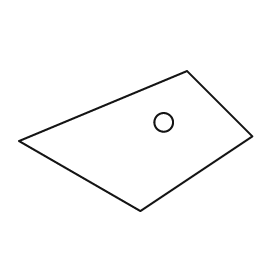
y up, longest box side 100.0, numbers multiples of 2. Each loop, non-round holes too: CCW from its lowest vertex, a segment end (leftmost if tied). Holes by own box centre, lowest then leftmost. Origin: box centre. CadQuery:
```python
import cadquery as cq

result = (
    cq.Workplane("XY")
    .moveTo(2.0, -30.0)
    .lineTo(50.0, 2.0)
    .lineTo(22.0, 30.0)
    .lineTo(-50.0, 0.0)
    .close()
    .moveTo(12.0, 8.0)
    .circle(4.0)
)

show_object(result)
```